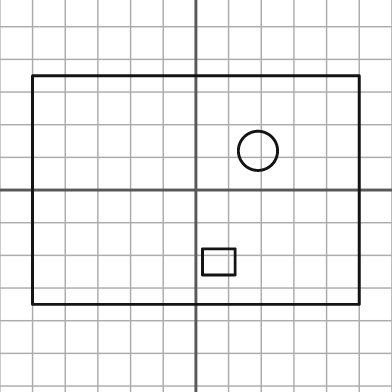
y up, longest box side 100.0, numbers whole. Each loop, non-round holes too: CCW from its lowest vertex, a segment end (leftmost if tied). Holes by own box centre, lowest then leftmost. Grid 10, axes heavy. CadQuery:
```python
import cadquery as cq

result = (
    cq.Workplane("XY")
    .moveTo(-50.0, -35.0)
    .lineTo(50.0, -35.0)
    .lineTo(50.0, 35.0)
    .lineTo(-50.0, 35.0)
    .close()
    .moveTo(2.0, -26.0)
    .lineTo(12.0, -26.0)
    .lineTo(12.0, -18.0)
    .lineTo(2.0, -18.0)
    .close()
    .moveTo(19.0, 12.0)
    .circle(6.0)
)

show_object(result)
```